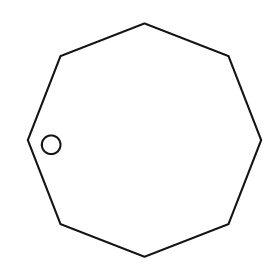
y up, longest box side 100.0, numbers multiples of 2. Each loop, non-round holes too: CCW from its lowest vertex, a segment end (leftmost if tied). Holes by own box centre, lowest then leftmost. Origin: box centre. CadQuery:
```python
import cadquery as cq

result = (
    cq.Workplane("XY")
    .moveTo(0.0, -50.0)
    .lineTo(36.0, -36.0)
    .lineTo(50.0, 0.0)
    .lineTo(36.0, 36.0)
    .lineTo(0.0, 50.0)
    .lineTo(-36.0, 36.0)
    .lineTo(-50.0, 0.0)
    .lineTo(-36.0, -36.0)
    .close()
    .moveTo(-40.0, -2.0)
    .circle(4.0)
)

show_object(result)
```